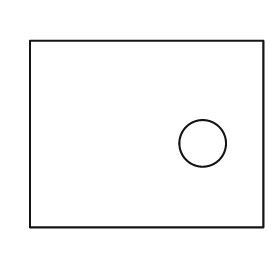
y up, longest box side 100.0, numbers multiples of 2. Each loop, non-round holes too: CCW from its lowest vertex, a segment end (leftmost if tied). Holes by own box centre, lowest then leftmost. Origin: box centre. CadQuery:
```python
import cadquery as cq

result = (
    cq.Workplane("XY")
    .moveTo(-50.0, -40.0)
    .lineTo(50.0, -40.0)
    .lineTo(50.0, 40.0)
    .lineTo(-50.0, 40.0)
    .close()
    .moveTo(24.0, -4.0)
    .circle(10.0)
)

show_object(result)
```